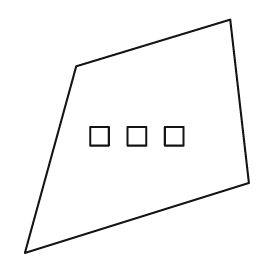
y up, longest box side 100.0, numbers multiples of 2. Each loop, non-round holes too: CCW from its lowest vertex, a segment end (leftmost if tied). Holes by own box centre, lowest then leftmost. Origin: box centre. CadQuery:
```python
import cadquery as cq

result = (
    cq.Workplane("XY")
    .moveTo(-48.0, -50.0)
    .lineTo(48.0, -20.0)
    .lineTo(40.0, 50.0)
    .lineTo(-26.0, 30.0)
    .close()
    .moveTo(-20.0, -4.0)
    .lineTo(-12.0, -4.0)
    .lineTo(-12.0, 4.0)
    .lineTo(-20.0, 4.0)
    .close()
    .moveTo(-4.0, -4.0)
    .lineTo(4.0, -4.0)
    .lineTo(4.0, 4.0)
    .lineTo(-4.0, 4.0)
    .close()
    .moveTo(12.0, -4.0)
    .lineTo(20.0, -4.0)
    .lineTo(20.0, 4.0)
    .lineTo(12.0, 4.0)
    .close()
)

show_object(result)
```